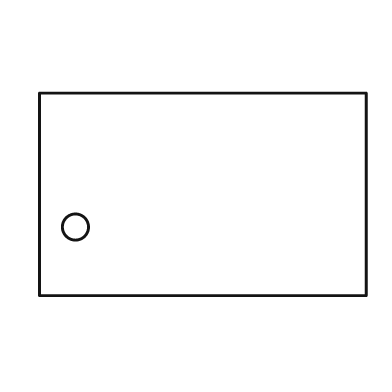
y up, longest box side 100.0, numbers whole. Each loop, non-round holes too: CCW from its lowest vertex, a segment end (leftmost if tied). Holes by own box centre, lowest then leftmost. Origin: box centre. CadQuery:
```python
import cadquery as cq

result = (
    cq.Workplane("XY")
    .moveTo(-50.0, -31.0)
    .lineTo(50.0, -31.0)
    .lineTo(50.0, 31.0)
    .lineTo(-50.0, 31.0)
    .close()
    .moveTo(-39.0, -10.0)
    .circle(4.0)
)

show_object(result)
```